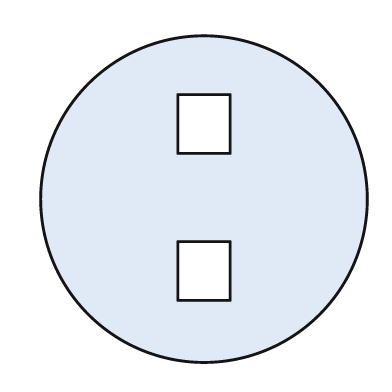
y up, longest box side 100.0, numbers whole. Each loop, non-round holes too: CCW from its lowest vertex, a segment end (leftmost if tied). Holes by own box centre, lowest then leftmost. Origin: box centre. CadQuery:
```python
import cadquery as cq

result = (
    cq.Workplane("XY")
    .moveTo(0.0, 0.0)
    .circle(50.0)
    .moveTo(-8.0, -31.0)
    .lineTo(8.0, -31.0)
    .lineTo(8.0, -13.0)
    .lineTo(-8.0, -13.0)
    .close()
    .moveTo(-8.0, 14.0)
    .lineTo(8.0, 14.0)
    .lineTo(8.0, 32.0)
    .lineTo(-8.0, 32.0)
    .close()
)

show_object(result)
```